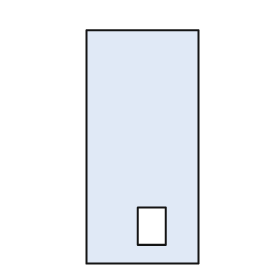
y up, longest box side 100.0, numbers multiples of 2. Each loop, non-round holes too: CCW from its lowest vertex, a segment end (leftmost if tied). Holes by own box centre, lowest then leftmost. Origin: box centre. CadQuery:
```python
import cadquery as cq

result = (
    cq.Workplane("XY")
    .moveTo(-24.0, -50.0)
    .lineTo(24.0, -50.0)
    .lineTo(24.0, 50.0)
    .lineTo(-24.0, 50.0)
    .close()
    .moveTo(-2.0, -42.0)
    .lineTo(10.0, -42.0)
    .lineTo(10.0, -26.0)
    .lineTo(-2.0, -26.0)
    .close()
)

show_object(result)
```